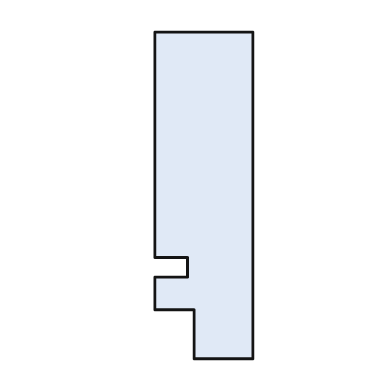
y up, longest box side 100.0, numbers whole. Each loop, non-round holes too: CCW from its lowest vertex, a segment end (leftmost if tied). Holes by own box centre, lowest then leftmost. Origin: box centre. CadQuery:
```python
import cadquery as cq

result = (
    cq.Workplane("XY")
    .moveTo(-3.0, -50.0)
    .lineTo(15.0, -50.0)
    .lineTo(15.0, 50.0)
    .lineTo(-15.0, 50.0)
    .lineTo(-15.0, -19.0)
    .lineTo(-5.0, -19.0)
    .lineTo(-5.0, -25.0)
    .lineTo(-15.0, -25.0)
    .lineTo(-15.0, -35.0)
    .lineTo(-3.0, -35.0)
    .close()
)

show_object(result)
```